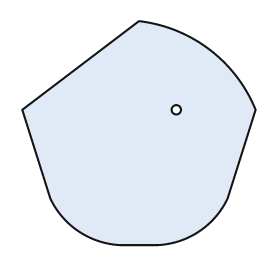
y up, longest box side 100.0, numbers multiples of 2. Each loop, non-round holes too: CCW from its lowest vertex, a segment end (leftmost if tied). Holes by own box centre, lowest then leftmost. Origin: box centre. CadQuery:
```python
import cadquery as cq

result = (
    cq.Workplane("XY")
    .moveTo(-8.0, -48.0)
    .lineTo(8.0, -48.0)
    .threePointArc((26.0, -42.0), (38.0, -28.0))
    .lineTo(50.0, 10.0)
    .threePointArc((30.0, 36.0), (0.0, 48.0))
    .lineTo(-50.0, 10.0)
    .lineTo(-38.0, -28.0)
    .threePointArc((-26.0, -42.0), (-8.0, -48.0))
    .close()
    .moveTo(16.0, 10.0)
    .circle(2.0)
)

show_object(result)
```